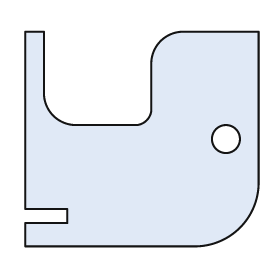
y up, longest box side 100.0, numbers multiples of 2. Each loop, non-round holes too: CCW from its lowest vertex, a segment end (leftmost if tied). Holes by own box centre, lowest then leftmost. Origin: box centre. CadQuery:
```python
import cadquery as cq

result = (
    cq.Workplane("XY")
    .moveTo(-50.0, -46.0)
    .lineTo(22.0, -46.0)
    .threePointArc((42.0, -38.0), (50.0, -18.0))
    .lineTo(50.0, 46.0)
    .lineTo(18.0, 46.0)
    .threePointArc((8.0, 42.0), (4.0, 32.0))
    .lineTo(4.0, 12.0)
    .threePointArc((2.0, 8.0), (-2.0, 6.0))
    .lineTo(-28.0, 6.0)
    .threePointArc((-38.0, 10.0), (-42.0, 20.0))
    .lineTo(-42.0, 46.0)
    .lineTo(-50.0, 46.0)
    .lineTo(-50.0, -30.0)
    .lineTo(-32.0, -30.0)
    .lineTo(-32.0, -36.0)
    .lineTo(-50.0, -36.0)
    .close()
    .moveTo(36.0, 0.0)
    .circle(6.0)
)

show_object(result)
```